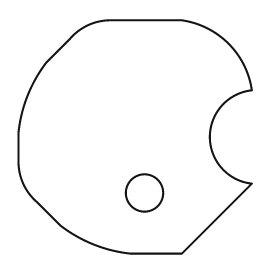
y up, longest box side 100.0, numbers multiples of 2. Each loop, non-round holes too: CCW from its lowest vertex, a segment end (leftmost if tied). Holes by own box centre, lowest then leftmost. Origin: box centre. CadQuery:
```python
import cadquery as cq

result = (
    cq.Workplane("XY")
    .moveTo(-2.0, -50.0)
    .lineTo(20.0, -50.0)
    .lineTo(50.0, -20.0)
    .threePointArc((32.0, 0.0), (50.0, 20.0))
    .threePointArc((40.0, 40.0), (20.0, 50.0))
    .lineTo(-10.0, 50.0)
    .threePointArc((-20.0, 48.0), (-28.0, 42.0))
    .lineTo(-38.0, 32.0)
    .threePointArc((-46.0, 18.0), (-50.0, 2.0))
    .lineTo(-50.0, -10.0)
    .threePointArc((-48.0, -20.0), (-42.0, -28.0))
    .lineTo(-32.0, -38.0)
    .threePointArc((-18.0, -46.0), (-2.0, -50.0))
    .close()
    .moveTo(4.0, -24.0)
    .circle(8.0)
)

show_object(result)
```